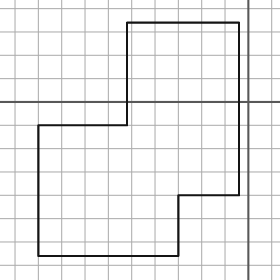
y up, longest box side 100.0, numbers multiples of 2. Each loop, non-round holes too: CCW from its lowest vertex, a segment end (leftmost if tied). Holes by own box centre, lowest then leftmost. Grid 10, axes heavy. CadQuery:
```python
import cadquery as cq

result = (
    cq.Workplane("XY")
    .moveTo(-90.0, -66.0)
    .lineTo(-30.0, -66.0)
    .lineTo(-30.0, -40.0)
    .lineTo(-4.0, -40.0)
    .lineTo(-4.0, 34.0)
    .lineTo(-52.0, 34.0)
    .lineTo(-52.0, -10.0)
    .lineTo(-90.0, -10.0)
    .close()
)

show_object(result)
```